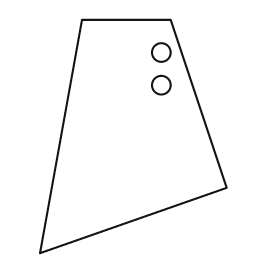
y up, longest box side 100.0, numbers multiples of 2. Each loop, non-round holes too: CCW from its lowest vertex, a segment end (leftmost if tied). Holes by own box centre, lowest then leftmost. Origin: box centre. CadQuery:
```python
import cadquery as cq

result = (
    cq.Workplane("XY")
    .moveTo(-40.0, -50.0)
    .lineTo(40.0, -22.0)
    .lineTo(16.0, 50.0)
    .lineTo(-22.0, 50.0)
    .close()
    .moveTo(12.0, 22.0)
    .circle(4.0)
    .moveTo(12.0, 36.0)
    .circle(4.0)
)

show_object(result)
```